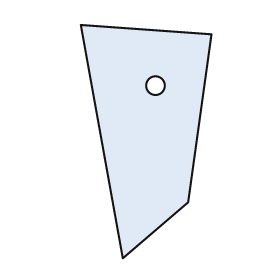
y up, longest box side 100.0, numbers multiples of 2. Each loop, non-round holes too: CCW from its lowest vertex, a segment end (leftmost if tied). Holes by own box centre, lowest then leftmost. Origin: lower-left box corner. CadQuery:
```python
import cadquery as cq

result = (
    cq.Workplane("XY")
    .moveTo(18.0, 0.0)
    .lineTo(46.0, 24.0)
    .lineTo(56.0, 96.0)
    .lineTo(0.0, 100.0)
    .close()
    .moveTo(32.0, 74.0)
    .circle(4.0)
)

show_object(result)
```